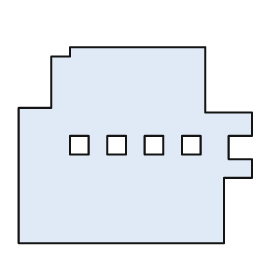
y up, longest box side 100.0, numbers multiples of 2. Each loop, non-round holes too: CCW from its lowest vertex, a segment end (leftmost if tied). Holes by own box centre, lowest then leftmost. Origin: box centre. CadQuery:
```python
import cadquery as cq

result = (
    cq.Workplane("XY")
    .moveTo(-50.0, -42.0)
    .lineTo(38.0, -42.0)
    .lineTo(38.0, -14.0)
    .lineTo(50.0, -14.0)
    .lineTo(50.0, -6.0)
    .lineTo(40.0, -6.0)
    .lineTo(40.0, 4.0)
    .lineTo(50.0, 4.0)
    .lineTo(50.0, 14.0)
    .lineTo(30.0, 14.0)
    .lineTo(30.0, 42.0)
    .lineTo(-28.0, 42.0)
    .lineTo(-28.0, 38.0)
    .lineTo(-36.0, 38.0)
    .lineTo(-36.0, 16.0)
    .lineTo(-50.0, 16.0)
    .close()
    .moveTo(-28.0, -4.0)
    .lineTo(-20.0, -4.0)
    .lineTo(-20.0, 4.0)
    .lineTo(-28.0, 4.0)
    .close()
    .moveTo(-12.0, -4.0)
    .lineTo(-4.0, -4.0)
    .lineTo(-4.0, 4.0)
    .lineTo(-12.0, 4.0)
    .close()
    .moveTo(4.0, -4.0)
    .lineTo(12.0, -4.0)
    .lineTo(12.0, 4.0)
    .lineTo(4.0, 4.0)
    .close()
    .moveTo(20.0, -4.0)
    .lineTo(28.0, -4.0)
    .lineTo(28.0, 4.0)
    .lineTo(20.0, 4.0)
    .close()
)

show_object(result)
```